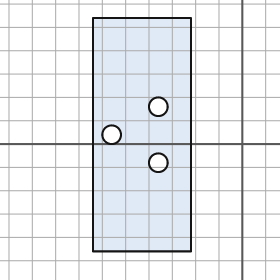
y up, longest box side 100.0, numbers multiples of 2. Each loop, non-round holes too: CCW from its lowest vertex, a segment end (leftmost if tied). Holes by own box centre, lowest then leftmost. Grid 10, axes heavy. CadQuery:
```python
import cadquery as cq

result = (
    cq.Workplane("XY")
    .moveTo(-64.0, -46.0)
    .lineTo(-22.0, -46.0)
    .lineTo(-22.0, 54.0)
    .lineTo(-64.0, 54.0)
    .close()
    .moveTo(-36.0, -8.0)
    .circle(4.0)
    .moveTo(-56.0, 4.0)
    .circle(4.0)
    .moveTo(-36.0, 16.0)
    .circle(4.0)
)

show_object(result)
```